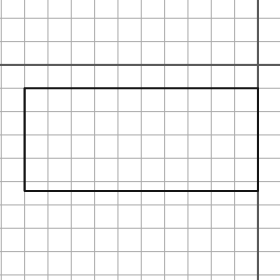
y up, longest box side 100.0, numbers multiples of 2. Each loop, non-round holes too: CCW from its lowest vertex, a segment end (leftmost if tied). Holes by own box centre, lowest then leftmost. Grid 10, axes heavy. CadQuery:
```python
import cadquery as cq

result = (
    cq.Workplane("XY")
    .moveTo(-100.0, -54.0)
    .lineTo(0.0, -54.0)
    .lineTo(0.0, -10.0)
    .lineTo(-100.0, -10.0)
    .close()
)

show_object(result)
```